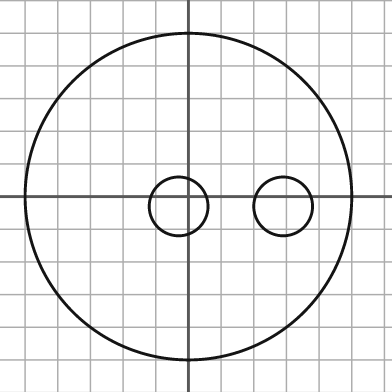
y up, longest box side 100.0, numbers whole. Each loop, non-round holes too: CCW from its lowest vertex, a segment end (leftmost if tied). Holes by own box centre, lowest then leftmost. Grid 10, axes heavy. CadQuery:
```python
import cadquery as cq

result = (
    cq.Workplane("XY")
    .moveTo(0.0, 0.0)
    .circle(50.0)
    .moveTo(-3.0, -3.0)
    .circle(9.0)
    .moveTo(29.0, -3.0)
    .circle(9.0)
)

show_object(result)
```